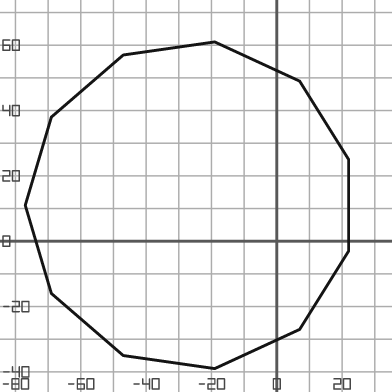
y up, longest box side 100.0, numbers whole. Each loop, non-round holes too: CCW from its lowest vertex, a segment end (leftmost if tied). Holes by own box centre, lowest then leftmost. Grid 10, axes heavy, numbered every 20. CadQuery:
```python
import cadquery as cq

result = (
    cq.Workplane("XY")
    .moveTo(-19.0, -39.0)
    .lineTo(7.0, -27.0)
    .lineTo(22.0, -3.0)
    .lineTo(22.0, 25.0)
    .lineTo(7.0, 49.0)
    .lineTo(-19.0, 61.0)
    .lineTo(-47.0, 57.0)
    .lineTo(-69.0, 38.0)
    .lineTo(-77.0, 11.0)
    .lineTo(-69.0, -16.0)
    .lineTo(-47.0, -35.0)
    .close()
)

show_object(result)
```